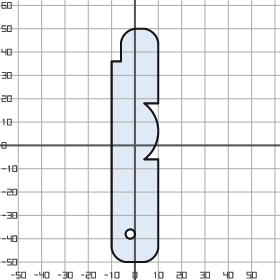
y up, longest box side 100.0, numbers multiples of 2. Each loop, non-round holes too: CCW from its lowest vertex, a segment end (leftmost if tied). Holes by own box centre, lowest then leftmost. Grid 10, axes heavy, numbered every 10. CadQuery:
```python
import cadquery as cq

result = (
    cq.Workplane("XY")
    .moveTo(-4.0, -50.0)
    .lineTo(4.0, -50.0)
    .threePointArc((8.0, -48.0), (10.0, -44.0))
    .lineTo(10.0, -6.0)
    .lineTo(4.0, -6.0)
    .threePointArc((10.0, 6.0), (4.0, 18.0))
    .lineTo(10.0, 18.0)
    .lineTo(10.0, 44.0)
    .threePointArc((8.0, 48.0), (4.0, 50.0))
    .lineTo(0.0, 50.0)
    .threePointArc((-4.0, 48.0), (-6.0, 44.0))
    .lineTo(-6.0, 36.0)
    .lineTo(-10.0, 36.0)
    .lineTo(-10.0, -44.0)
    .threePointArc((-8.0, -48.0), (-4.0, -50.0))
    .close()
    .moveTo(-2.0, -38.0)
    .circle(2.0)
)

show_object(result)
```